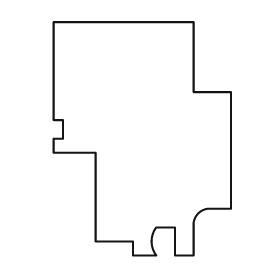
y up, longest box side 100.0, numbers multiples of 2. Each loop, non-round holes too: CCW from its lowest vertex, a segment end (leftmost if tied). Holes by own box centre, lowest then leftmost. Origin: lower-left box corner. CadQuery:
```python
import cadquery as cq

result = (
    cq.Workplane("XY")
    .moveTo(34.0, 0.0)
    .lineTo(44.0, 0.0)
    .threePointArc((42.0, 6.0), (44.0, 12.0))
    .lineTo(52.0, 12.0)
    .lineTo(52.0, 0.0)
    .lineTo(60.0, 0.0)
    .lineTo(60.0, 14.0)
    .threePointArc((62.0, 18.0), (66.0, 20.0))
    .lineTo(76.0, 20.0)
    .lineTo(76.0, 70.0)
    .lineTo(60.0, 70.0)
    .lineTo(60.0, 100.0)
    .lineTo(0.0, 100.0)
    .lineTo(0.0, 58.0)
    .lineTo(4.0, 58.0)
    .lineTo(4.0, 50.0)
    .lineTo(0.0, 50.0)
    .lineTo(0.0, 44.0)
    .lineTo(18.0, 44.0)
    .lineTo(18.0, 6.0)
    .lineTo(34.0, 6.0)
    .close()
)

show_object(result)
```